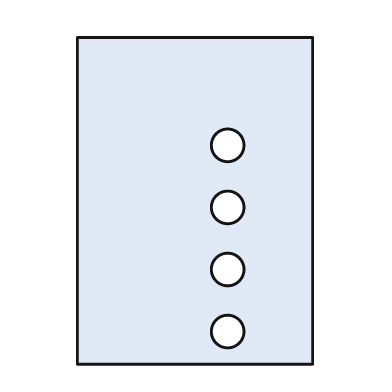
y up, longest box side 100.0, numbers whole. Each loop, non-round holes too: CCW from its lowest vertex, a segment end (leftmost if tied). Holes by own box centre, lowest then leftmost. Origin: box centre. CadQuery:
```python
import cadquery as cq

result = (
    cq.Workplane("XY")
    .moveTo(-36.0, -50.0)
    .lineTo(36.0, -50.0)
    .lineTo(36.0, 50.0)
    .lineTo(-36.0, 50.0)
    .close()
    .moveTo(10.0, -40.0)
    .circle(5.0)
    .moveTo(10.0, -21.0)
    .circle(5.0)
    .moveTo(10.0, -2.0)
    .circle(5.0)
    .moveTo(10.0, 17.0)
    .circle(5.0)
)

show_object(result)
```